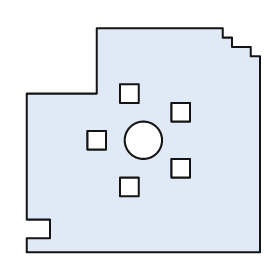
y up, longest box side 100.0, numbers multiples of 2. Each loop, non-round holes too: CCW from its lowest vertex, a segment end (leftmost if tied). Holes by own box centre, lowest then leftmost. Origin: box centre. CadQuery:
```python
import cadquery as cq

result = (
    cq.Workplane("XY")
    .moveTo(-50.0, -48.0)
    .lineTo(50.0, -48.0)
    .lineTo(50.0, 36.0)
    .lineTo(46.0, 36.0)
    .lineTo(46.0, 40.0)
    .lineTo(38.0, 40.0)
    .lineTo(38.0, 44.0)
    .lineTo(34.0, 44.0)
    .lineTo(34.0, 48.0)
    .lineTo(-20.0, 48.0)
    .lineTo(-20.0, 20.0)
    .lineTo(-50.0, 20.0)
    .lineTo(-50.0, -34.0)
    .lineTo(-40.0, -34.0)
    .lineTo(-40.0, -42.0)
    .lineTo(-50.0, -42.0)
    .close()
    .moveTo(-10.0, -24.0)
    .lineTo(-2.0, -24.0)
    .lineTo(-2.0, -16.0)
    .lineTo(-10.0, -16.0)
    .close()
    .moveTo(12.0, -16.0)
    .lineTo(20.0, -16.0)
    .lineTo(20.0, -8.0)
    .lineTo(12.0, -8.0)
    .close()
    .moveTo(-24.0, -4.0)
    .lineTo(-16.0, -4.0)
    .lineTo(-16.0, 4.0)
    .lineTo(-24.0, 4.0)
    .close()
    .moveTo(0.0, 0.0)
    .circle(8.0)
    .moveTo(12.0, 8.0)
    .lineTo(20.0, 8.0)
    .lineTo(20.0, 16.0)
    .lineTo(12.0, 16.0)
    .close()
    .moveTo(-10.0, 16.0)
    .lineTo(-2.0, 16.0)
    .lineTo(-2.0, 24.0)
    .lineTo(-10.0, 24.0)
    .close()
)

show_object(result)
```